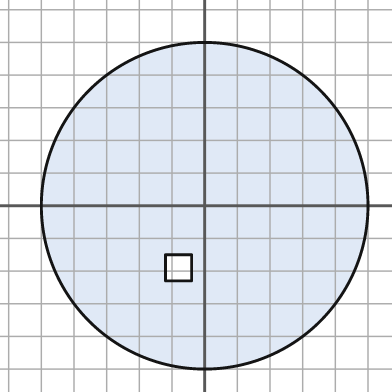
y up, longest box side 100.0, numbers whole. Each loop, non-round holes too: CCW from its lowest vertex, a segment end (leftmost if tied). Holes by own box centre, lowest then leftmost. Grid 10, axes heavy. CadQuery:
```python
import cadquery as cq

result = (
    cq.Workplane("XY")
    .moveTo(0.0, 0.0)
    .circle(50.0)
    .moveTo(-12.0, -23.0)
    .lineTo(-4.0, -23.0)
    .lineTo(-4.0, -15.0)
    .lineTo(-12.0, -15.0)
    .close()
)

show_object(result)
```